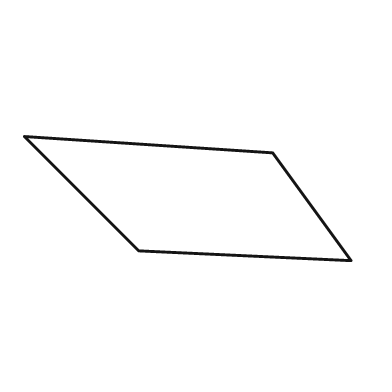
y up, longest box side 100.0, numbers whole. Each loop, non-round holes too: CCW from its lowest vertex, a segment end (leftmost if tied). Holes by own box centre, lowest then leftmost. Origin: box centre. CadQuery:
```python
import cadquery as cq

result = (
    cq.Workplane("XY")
    .moveTo(50.0, -19.0)
    .lineTo(26.0, 14.0)
    .lineTo(-50.0, 19.0)
    .lineTo(-15.0, -16.0)
    .close()
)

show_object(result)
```